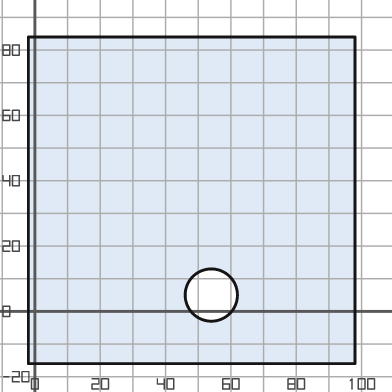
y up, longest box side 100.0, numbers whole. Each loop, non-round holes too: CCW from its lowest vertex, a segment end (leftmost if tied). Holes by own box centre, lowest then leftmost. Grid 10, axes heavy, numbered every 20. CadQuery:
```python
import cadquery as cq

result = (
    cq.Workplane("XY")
    .moveTo(-2.0, -16.0)
    .lineTo(98.0, -16.0)
    .lineTo(98.0, 84.0)
    .lineTo(-2.0, 84.0)
    .close()
    .moveTo(54.0, 5.0)
    .circle(8.0)
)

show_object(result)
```